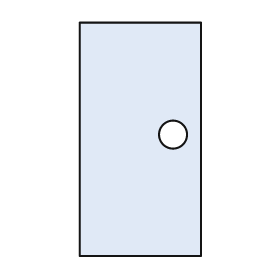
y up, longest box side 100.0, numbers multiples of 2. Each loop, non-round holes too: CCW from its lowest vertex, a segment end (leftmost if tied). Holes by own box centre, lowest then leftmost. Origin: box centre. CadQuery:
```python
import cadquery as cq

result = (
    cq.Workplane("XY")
    .moveTo(-26.0, -50.0)
    .lineTo(26.0, -50.0)
    .lineTo(26.0, 50.0)
    .lineTo(-26.0, 50.0)
    .close()
    .moveTo(14.0, 2.0)
    .circle(6.0)
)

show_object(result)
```